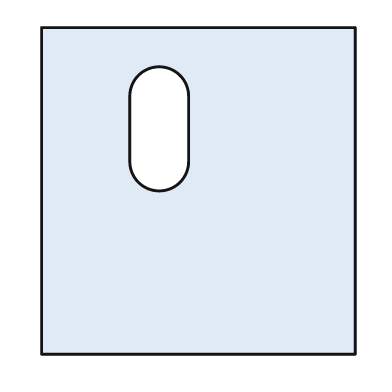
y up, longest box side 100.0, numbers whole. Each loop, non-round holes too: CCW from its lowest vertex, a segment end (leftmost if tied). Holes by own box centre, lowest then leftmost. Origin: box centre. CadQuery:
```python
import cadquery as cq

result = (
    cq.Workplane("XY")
    .moveTo(-48.0, -50.0)
    .lineTo(48.0, -50.0)
    .lineTo(48.0, 50.0)
    .lineTo(-48.0, 50.0)
    .close()
    .moveTo(-21.0, 9.0)
    .threePointArc((-12.0, 0.0), (-3.0, 9.0))
    .lineTo(-3.0, 29.0)
    .threePointArc((-12.0, 38.0), (-21.0, 29.0))
    .close()
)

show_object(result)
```